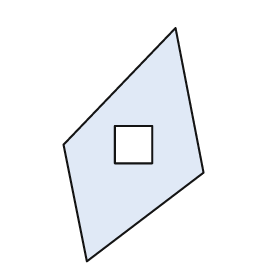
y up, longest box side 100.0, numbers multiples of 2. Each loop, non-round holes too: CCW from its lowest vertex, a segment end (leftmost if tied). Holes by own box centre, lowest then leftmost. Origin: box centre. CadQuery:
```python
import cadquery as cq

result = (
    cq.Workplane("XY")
    .moveTo(-20.0, -50.0)
    .lineTo(30.0, -12.0)
    .lineTo(18.0, 50.0)
    .lineTo(-30.0, 0.0)
    .close()
    .moveTo(-8.0, -8.0)
    .lineTo(8.0, -8.0)
    .lineTo(8.0, 8.0)
    .lineTo(-8.0, 8.0)
    .close()
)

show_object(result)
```